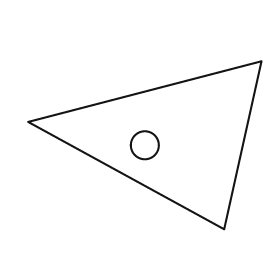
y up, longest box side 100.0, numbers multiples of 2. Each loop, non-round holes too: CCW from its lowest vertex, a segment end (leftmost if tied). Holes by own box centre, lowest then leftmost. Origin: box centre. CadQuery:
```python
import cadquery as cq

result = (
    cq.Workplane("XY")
    .moveTo(34.0, -36.0)
    .lineTo(50.0, 36.0)
    .lineTo(-50.0, 10.0)
    .close()
    .moveTo(0.0, 0.0)
    .circle(6.0)
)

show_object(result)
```